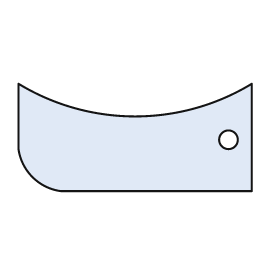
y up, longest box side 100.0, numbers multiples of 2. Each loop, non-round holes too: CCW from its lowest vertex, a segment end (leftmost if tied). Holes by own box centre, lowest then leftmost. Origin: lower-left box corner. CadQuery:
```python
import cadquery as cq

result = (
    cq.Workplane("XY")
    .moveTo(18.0, 0.0)
    .lineTo(100.0, 0.0)
    .lineTo(100.0, 46.0)
    .threePointArc((50.0, 32.0), (0.0, 46.0))
    .lineTo(0.0, 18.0)
    .threePointArc((6.0, 6.0), (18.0, 0.0))
    .close()
    .moveTo(90.0, 22.0)
    .circle(4.0)
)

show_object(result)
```